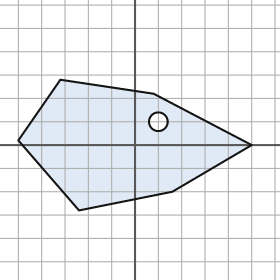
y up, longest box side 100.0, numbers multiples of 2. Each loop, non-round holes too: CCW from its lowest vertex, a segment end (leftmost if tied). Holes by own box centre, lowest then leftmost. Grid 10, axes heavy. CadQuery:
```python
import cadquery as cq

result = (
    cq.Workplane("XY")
    .moveTo(-24.0, -28.0)
    .lineTo(16.0, -20.0)
    .lineTo(50.0, 0.0)
    .lineTo(8.0, 22.0)
    .lineTo(-32.0, 28.0)
    .lineTo(-50.0, 2.0)
    .close()
    .moveTo(10.0, 10.0)
    .circle(4.0)
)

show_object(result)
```